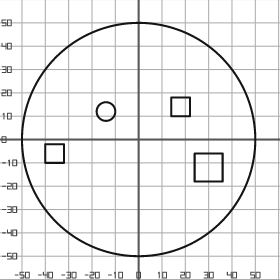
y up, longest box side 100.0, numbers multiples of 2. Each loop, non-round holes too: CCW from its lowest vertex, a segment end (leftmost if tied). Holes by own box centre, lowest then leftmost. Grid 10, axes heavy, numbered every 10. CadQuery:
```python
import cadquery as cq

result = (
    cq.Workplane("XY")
    .moveTo(0.0, 0.0)
    .circle(50.0)
    .moveTo(24.0, -18.0)
    .lineTo(36.0, -18.0)
    .lineTo(36.0, -6.0)
    .lineTo(24.0, -6.0)
    .close()
    .moveTo(-40.0, -10.0)
    .lineTo(-32.0, -10.0)
    .lineTo(-32.0, -2.0)
    .lineTo(-40.0, -2.0)
    .close()
    .moveTo(-14.0, 12.0)
    .circle(4.0)
    .moveTo(14.0, 10.0)
    .lineTo(22.0, 10.0)
    .lineTo(22.0, 18.0)
    .lineTo(14.0, 18.0)
    .close()
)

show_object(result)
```